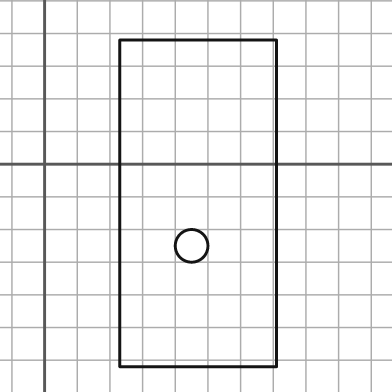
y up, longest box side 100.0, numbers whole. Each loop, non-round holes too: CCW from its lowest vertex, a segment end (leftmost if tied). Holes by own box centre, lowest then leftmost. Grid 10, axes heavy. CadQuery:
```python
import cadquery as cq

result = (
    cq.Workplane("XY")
    .moveTo(23.0, -62.0)
    .lineTo(71.0, -62.0)
    .lineTo(71.0, 38.0)
    .lineTo(23.0, 38.0)
    .close()
    .moveTo(45.0, -25.0)
    .circle(5.0)
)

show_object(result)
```